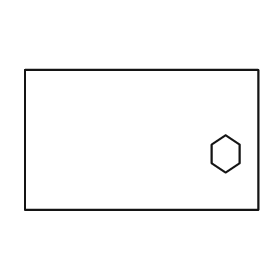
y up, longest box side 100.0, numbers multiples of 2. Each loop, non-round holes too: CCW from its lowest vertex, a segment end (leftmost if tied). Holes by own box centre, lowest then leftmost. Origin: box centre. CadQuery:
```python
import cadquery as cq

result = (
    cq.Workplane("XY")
    .moveTo(-50.0, -30.0)
    .lineTo(50.0, -30.0)
    .lineTo(50.0, 30.0)
    .lineTo(-50.0, 30.0)
    .close()
    .moveTo(36.0, -14.0)
    .lineTo(42.0, -10.0)
    .lineTo(42.0, -2.0)
    .lineTo(36.0, 2.0)
    .lineTo(30.0, -2.0)
    .lineTo(30.0, -10.0)
    .close()
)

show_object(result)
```